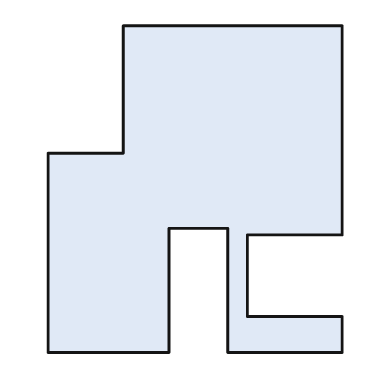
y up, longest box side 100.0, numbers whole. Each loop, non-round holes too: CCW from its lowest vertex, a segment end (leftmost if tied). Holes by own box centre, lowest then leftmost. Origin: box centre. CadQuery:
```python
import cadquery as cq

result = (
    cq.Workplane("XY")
    .moveTo(-45.0, -50.0)
    .lineTo(-8.0, -50.0)
    .lineTo(-8.0, -12.0)
    .lineTo(10.0, -12.0)
    .lineTo(10.0, -50.0)
    .lineTo(45.0, -50.0)
    .lineTo(45.0, -39.0)
    .lineTo(16.0, -39.0)
    .lineTo(16.0, -14.0)
    .lineTo(45.0, -14.0)
    .lineTo(45.0, 50.0)
    .lineTo(-22.0, 50.0)
    .lineTo(-22.0, 11.0)
    .lineTo(-45.0, 11.0)
    .close()
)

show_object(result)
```